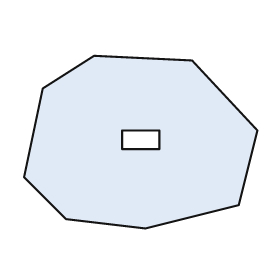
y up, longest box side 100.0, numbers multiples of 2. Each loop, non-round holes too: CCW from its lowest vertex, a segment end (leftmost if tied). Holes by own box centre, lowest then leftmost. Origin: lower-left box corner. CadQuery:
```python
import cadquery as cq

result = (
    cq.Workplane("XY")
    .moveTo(52.0, 0.0)
    .lineTo(92.0, 10.0)
    .lineTo(100.0, 42.0)
    .lineTo(72.0, 72.0)
    .lineTo(30.0, 74.0)
    .lineTo(8.0, 60.0)
    .lineTo(0.0, 22.0)
    .lineTo(18.0, 4.0)
    .close()
    .moveTo(42.0, 34.0)
    .lineTo(58.0, 34.0)
    .lineTo(58.0, 42.0)
    .lineTo(42.0, 42.0)
    .close()
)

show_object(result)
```